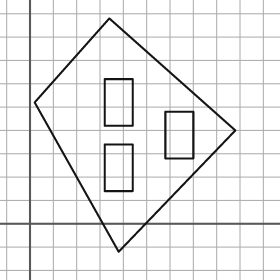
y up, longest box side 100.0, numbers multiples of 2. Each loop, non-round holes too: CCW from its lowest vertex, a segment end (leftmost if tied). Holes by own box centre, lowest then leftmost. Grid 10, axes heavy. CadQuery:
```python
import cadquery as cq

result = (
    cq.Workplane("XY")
    .moveTo(38.0, -12.0)
    .lineTo(88.0, 40.0)
    .lineTo(34.0, 88.0)
    .lineTo(2.0, 52.0)
    .close()
    .moveTo(32.0, 14.0)
    .lineTo(44.0, 14.0)
    .lineTo(44.0, 34.0)
    .lineTo(32.0, 34.0)
    .close()
    .moveTo(58.0, 28.0)
    .lineTo(70.0, 28.0)
    .lineTo(70.0, 48.0)
    .lineTo(58.0, 48.0)
    .close()
    .moveTo(32.0, 42.0)
    .lineTo(44.0, 42.0)
    .lineTo(44.0, 62.0)
    .lineTo(32.0, 62.0)
    .close()
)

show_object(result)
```